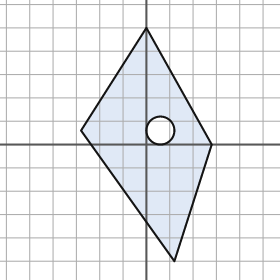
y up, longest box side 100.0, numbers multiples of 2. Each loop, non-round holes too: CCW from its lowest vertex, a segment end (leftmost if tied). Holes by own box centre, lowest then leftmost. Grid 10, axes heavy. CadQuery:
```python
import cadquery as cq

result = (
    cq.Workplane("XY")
    .moveTo(12.0, -50.0)
    .lineTo(28.0, 0.0)
    .lineTo(0.0, 50.0)
    .lineTo(-28.0, 6.0)
    .close()
    .moveTo(6.0, 6.0)
    .circle(6.0)
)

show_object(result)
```